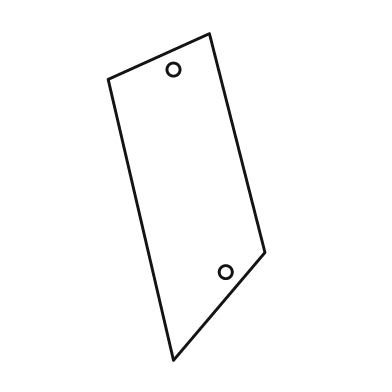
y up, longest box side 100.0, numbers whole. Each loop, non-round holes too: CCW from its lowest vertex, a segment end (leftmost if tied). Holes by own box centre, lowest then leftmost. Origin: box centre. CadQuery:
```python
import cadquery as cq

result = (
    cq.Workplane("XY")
    .moveTo(-4.0, -50.0)
    .lineTo(24.0, -17.0)
    .lineTo(7.0, 50.0)
    .lineTo(-24.0, 36.0)
    .close()
    .moveTo(12.0, -23.0)
    .circle(2.0)
    .moveTo(-4.0, 39.0)
    .circle(2.0)
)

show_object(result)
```